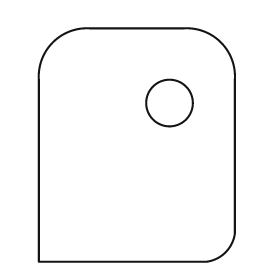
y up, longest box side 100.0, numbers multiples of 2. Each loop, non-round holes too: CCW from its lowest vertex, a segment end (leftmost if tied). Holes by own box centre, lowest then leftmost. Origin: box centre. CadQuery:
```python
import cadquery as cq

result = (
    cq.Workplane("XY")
    .moveTo(-42.0, -50.0)
    .lineTo(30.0, -50.0)
    .threePointArc((38.0, -46.0), (42.0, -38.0))
    .lineTo(42.0, 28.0)
    .threePointArc((36.0, 44.0), (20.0, 50.0))
    .lineTo(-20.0, 50.0)
    .threePointArc((-36.0, 44.0), (-42.0, 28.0))
    .close()
    .moveTo(14.0, 18.0)
    .circle(10.0)
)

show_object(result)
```